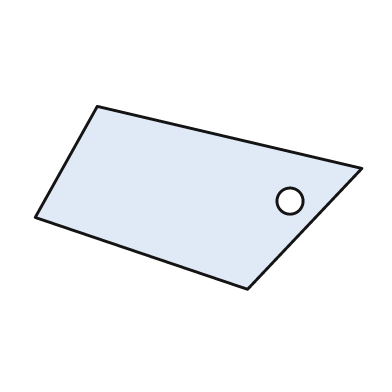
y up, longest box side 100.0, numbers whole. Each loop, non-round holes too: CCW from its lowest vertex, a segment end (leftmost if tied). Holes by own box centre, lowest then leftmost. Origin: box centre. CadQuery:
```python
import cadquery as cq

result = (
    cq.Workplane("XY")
    .moveTo(15.0, -28.0)
    .lineTo(50.0, 9.0)
    .lineTo(-31.0, 28.0)
    .lineTo(-50.0, -6.0)
    .close()
    .moveTo(28.0, -1.0)
    .circle(4.0)
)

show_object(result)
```